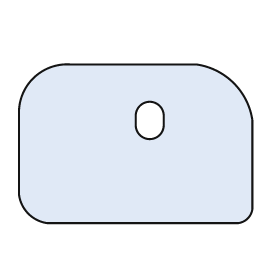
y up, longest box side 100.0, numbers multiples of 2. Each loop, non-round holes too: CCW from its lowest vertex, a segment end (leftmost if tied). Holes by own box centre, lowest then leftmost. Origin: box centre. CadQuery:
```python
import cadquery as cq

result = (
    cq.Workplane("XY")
    .moveTo(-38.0, -34.0)
    .lineTo(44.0, -34.0)
    .threePointArc((48.0, -32.0), (50.0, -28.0))
    .lineTo(50.0, 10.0)
    .threePointArc((42.0, 26.0), (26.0, 34.0))
    .lineTo(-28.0, 34.0)
    .threePointArc((-44.0, 28.0), (-50.0, 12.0))
    .lineTo(-50.0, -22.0)
    .threePointArc((-46.0, -30.0), (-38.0, -34.0))
    .close()
    .moveTo(0.0, 8.0)
    .threePointArc((6.0, 2.0), (12.0, 8.0))
    .lineTo(12.0, 12.0)
    .threePointArc((6.0, 18.0), (0.0, 12.0))
    .close()
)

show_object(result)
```